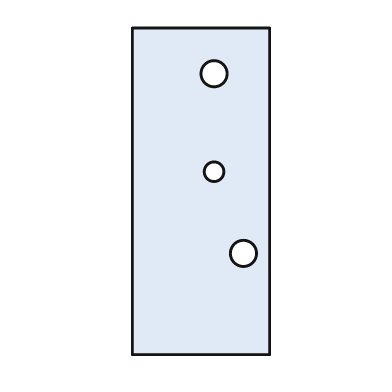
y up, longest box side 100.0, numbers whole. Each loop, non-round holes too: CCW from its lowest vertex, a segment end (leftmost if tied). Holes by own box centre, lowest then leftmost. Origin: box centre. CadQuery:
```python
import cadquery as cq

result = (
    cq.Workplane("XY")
    .moveTo(-21.0, -50.0)
    .lineTo(21.0, -50.0)
    .lineTo(21.0, 50.0)
    .lineTo(-21.0, 50.0)
    .close()
    .moveTo(13.0, -19.0)
    .circle(4.0)
    .moveTo(4.0, 6.0)
    .circle(3.0)
    .moveTo(4.0, 36.0)
    .circle(4.0)
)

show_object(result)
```